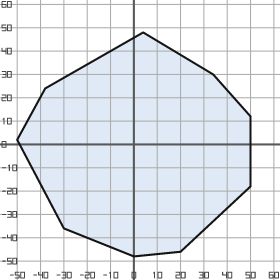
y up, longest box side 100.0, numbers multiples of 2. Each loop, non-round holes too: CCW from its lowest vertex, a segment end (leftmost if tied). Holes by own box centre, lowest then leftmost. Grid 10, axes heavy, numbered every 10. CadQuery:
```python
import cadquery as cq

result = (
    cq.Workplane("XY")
    .moveTo(0.0, -48.0)
    .lineTo(20.0, -46.0)
    .lineTo(50.0, -18.0)
    .lineTo(50.0, 12.0)
    .lineTo(34.0, 30.0)
    .lineTo(4.0, 48.0)
    .lineTo(-38.0, 24.0)
    .lineTo(-50.0, 2.0)
    .lineTo(-30.0, -36.0)
    .close()
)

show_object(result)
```